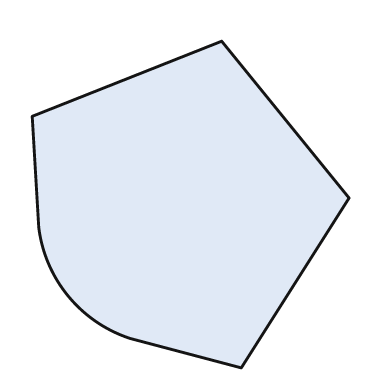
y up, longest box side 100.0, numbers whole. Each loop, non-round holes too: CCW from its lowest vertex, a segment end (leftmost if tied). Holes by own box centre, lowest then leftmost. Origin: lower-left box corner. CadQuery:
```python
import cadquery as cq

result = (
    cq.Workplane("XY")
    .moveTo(64.0, 0.0)
    .lineTo(97.0, 52.0)
    .lineTo(58.0, 100.0)
    .lineTo(0.0, 77.0)
    .lineTo(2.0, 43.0)
    .threePointArc((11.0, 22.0), (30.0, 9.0))
    .close()
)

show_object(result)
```